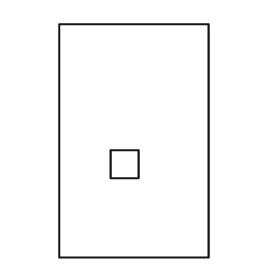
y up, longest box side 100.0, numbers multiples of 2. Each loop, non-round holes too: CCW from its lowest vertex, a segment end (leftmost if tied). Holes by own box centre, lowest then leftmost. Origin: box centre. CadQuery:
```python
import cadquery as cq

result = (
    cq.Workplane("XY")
    .moveTo(-32.0, -50.0)
    .lineTo(32.0, -50.0)
    .lineTo(32.0, 50.0)
    .lineTo(-32.0, 50.0)
    .close()
    .moveTo(-10.0, -16.0)
    .lineTo(2.0, -16.0)
    .lineTo(2.0, -4.0)
    .lineTo(-10.0, -4.0)
    .close()
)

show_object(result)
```